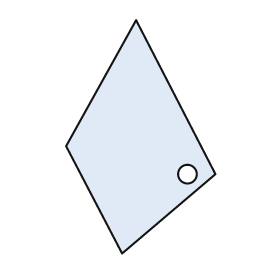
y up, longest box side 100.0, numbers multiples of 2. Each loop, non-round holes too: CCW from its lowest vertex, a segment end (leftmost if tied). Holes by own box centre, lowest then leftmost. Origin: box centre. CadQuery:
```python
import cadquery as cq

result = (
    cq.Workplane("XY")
    .moveTo(-8.0, -50.0)
    .lineTo(32.0, -16.0)
    .lineTo(-2.0, 50.0)
    .lineTo(-32.0, -4.0)
    .close()
    .moveTo(20.0, -16.0)
    .circle(4.0)
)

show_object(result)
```